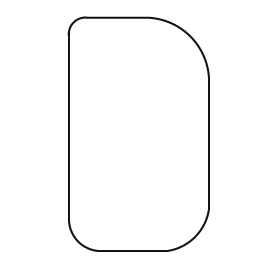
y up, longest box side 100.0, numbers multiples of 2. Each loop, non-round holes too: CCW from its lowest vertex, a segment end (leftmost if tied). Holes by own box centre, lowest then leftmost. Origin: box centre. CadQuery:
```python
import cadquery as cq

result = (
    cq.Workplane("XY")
    .moveTo(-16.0, -50.0)
    .lineTo(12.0, -50.0)
    .threePointArc((24.0, -44.0), (30.0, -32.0))
    .lineTo(30.0, 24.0)
    .threePointArc((22.0, 42.0), (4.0, 50.0))
    .lineTo(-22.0, 50.0)
    .threePointArc((-28.0, 48.0), (-30.0, 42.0))
    .lineTo(-30.0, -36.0)
    .threePointArc((-26.0, -46.0), (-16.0, -50.0))
    .close()
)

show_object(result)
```